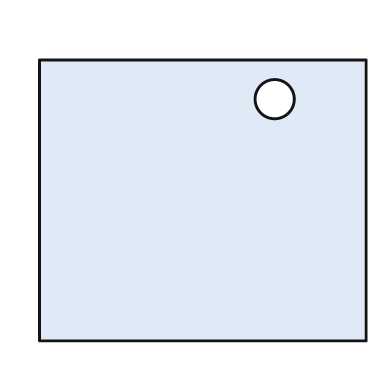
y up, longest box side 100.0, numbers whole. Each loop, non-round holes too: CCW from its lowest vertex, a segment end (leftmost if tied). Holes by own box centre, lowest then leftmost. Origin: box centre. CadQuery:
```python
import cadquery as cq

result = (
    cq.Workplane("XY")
    .moveTo(-50.0, -43.0)
    .lineTo(50.0, -43.0)
    .lineTo(50.0, 43.0)
    .lineTo(-50.0, 43.0)
    .close()
    .moveTo(22.0, 31.0)
    .circle(6.0)
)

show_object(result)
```